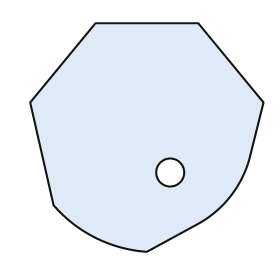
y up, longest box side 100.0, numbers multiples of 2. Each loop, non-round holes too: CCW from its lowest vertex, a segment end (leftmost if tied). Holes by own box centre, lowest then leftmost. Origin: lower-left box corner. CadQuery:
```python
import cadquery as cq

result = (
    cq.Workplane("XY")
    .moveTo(50.0, 0.0)
    .lineTo(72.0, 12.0)
    .threePointArc((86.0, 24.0), (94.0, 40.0))
    .lineTo(100.0, 64.0)
    .lineTo(72.0, 98.0)
    .lineTo(28.0, 98.0)
    .lineTo(0.0, 64.0)
    .lineTo(10.0, 20.0)
    .threePointArc((28.0, 6.0), (50.0, 0.0))
    .close()
    .moveTo(60.0, 34.0)
    .circle(6.0)
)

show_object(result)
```